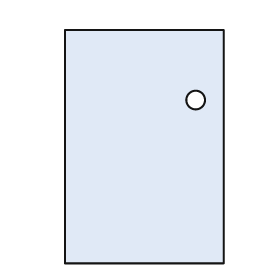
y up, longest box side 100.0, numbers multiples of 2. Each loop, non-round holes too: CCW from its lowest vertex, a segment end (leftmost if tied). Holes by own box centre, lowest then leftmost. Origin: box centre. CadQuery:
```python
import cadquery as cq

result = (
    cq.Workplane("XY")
    .moveTo(-34.0, -50.0)
    .lineTo(34.0, -50.0)
    .lineTo(34.0, 50.0)
    .lineTo(-34.0, 50.0)
    .close()
    .moveTo(22.0, 20.0)
    .circle(4.0)
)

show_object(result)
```